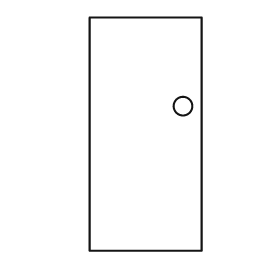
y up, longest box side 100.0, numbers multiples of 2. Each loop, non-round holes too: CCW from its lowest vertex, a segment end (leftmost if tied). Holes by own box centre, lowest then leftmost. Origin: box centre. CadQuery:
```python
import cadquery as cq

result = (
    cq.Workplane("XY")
    .moveTo(-24.0, -50.0)
    .lineTo(24.0, -50.0)
    .lineTo(24.0, 50.0)
    .lineTo(-24.0, 50.0)
    .close()
    .moveTo(16.0, 12.0)
    .circle(4.0)
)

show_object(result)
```